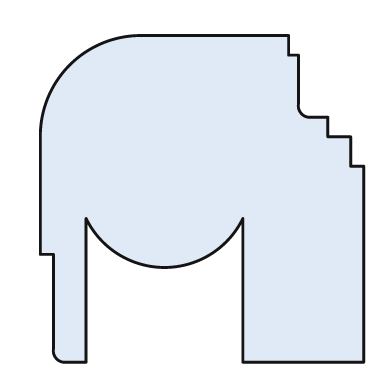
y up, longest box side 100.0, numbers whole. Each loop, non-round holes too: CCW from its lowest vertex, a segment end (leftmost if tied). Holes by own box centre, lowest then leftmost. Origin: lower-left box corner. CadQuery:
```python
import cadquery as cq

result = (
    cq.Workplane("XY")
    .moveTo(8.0, 0.0)
    .lineTo(14.0, 0.0)
    .lineTo(14.0, 44.0)
    .threePointArc((38.0, 29.0), (62.0, 44.0))
    .lineTo(62.0, 0.0)
    .lineTo(99.0, 0.0)
    .lineTo(99.0, 60.0)
    .lineTo(95.0, 60.0)
    .lineTo(95.0, 69.0)
    .lineTo(88.0, 69.0)
    .lineTo(88.0, 75.0)
    .lineTo(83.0, 75.0)
    .threePointArc((80.0, 76.0), (79.0, 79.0))
    .lineTo(79.0, 94.0)
    .lineTo(76.0, 94.0)
    .lineTo(76.0, 100.0)
    .lineTo(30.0, 100.0)
    .threePointArc((9.0, 91.0), (0.0, 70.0))
    .lineTo(0.0, 33.0)
    .lineTo(4.0, 33.0)
    .lineTo(4.0, 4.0)
    .threePointArc((5.0, 1.0), (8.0, 0.0))
    .close()
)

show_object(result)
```